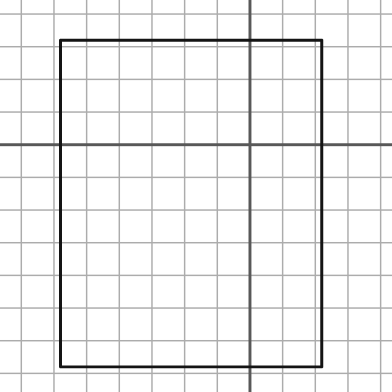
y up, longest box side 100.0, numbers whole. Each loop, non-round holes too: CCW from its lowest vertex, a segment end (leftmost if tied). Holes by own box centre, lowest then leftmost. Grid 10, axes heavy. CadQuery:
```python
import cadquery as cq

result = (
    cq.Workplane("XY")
    .moveTo(-58.0, -68.0)
    .lineTo(22.0, -68.0)
    .lineTo(22.0, 32.0)
    .lineTo(-58.0, 32.0)
    .close()
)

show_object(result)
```